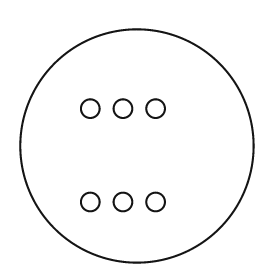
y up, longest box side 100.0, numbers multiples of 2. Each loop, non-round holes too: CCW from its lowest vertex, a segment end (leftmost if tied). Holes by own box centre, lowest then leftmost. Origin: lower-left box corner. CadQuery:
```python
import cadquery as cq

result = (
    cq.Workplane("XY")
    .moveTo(50.0, 50.0)
    .circle(50.0)
    .moveTo(30.0, 26.0)
    .circle(4.0)
    .moveTo(44.0, 26.0)
    .circle(4.0)
    .moveTo(58.0, 26.0)
    .circle(4.0)
    .moveTo(30.0, 66.0)
    .circle(4.0)
    .moveTo(44.0, 66.0)
    .circle(4.0)
    .moveTo(58.0, 66.0)
    .circle(4.0)
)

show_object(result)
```